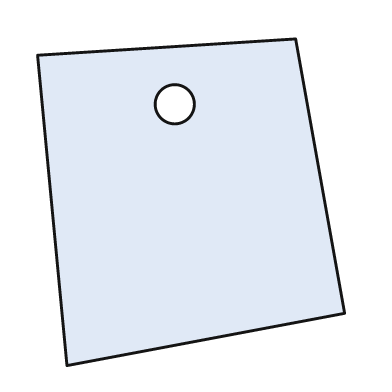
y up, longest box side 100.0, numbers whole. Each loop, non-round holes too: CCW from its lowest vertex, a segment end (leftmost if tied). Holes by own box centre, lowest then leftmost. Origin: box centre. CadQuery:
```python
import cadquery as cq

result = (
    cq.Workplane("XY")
    .moveTo(-38.0, -50.0)
    .lineTo(47.0, -34.0)
    .lineTo(32.0, 50.0)
    .lineTo(-47.0, 45.0)
    .close()
    .moveTo(-5.0, 30.0)
    .circle(6.0)
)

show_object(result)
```